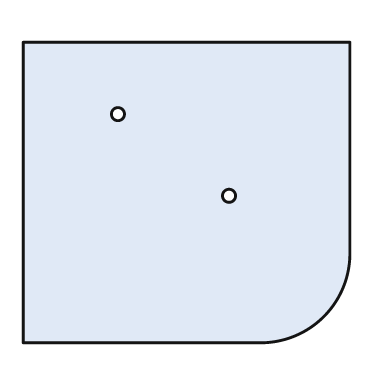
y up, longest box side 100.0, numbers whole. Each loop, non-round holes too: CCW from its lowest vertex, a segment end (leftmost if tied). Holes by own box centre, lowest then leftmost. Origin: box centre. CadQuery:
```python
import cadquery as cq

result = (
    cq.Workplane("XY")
    .moveTo(-50.0, -46.0)
    .lineTo(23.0, -46.0)
    .threePointArc((42.0, -38.0), (50.0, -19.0))
    .lineTo(50.0, 46.0)
    .lineTo(-50.0, 46.0)
    .close()
    .moveTo(13.0, -1.0)
    .circle(2.0)
    .moveTo(-21.0, 24.0)
    .circle(2.0)
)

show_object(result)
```